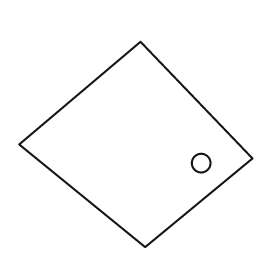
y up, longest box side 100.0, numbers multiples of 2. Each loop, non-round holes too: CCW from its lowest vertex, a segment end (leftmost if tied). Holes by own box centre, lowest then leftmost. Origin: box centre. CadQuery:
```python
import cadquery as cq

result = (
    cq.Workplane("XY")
    .moveTo(4.0, -44.0)
    .lineTo(50.0, -6.0)
    .lineTo(2.0, 44.0)
    .lineTo(-50.0, 0.0)
    .close()
    .moveTo(28.0, -8.0)
    .circle(4.0)
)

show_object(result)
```